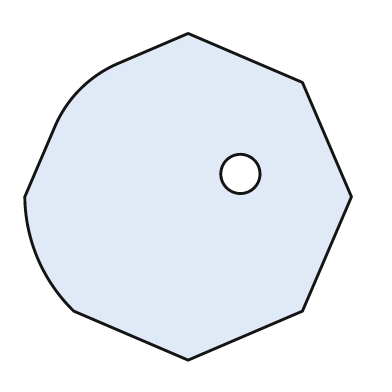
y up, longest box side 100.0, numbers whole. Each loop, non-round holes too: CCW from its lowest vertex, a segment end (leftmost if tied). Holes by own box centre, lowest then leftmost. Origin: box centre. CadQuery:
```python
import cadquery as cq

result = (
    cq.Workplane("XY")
    .moveTo(0.0, -50.0)
    .lineTo(35.0, -35.0)
    .lineTo(50.0, 0.0)
    .lineTo(35.0, 35.0)
    .lineTo(0.0, 50.0)
    .lineTo(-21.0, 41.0)
    .threePointArc((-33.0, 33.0), (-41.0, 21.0))
    .lineTo(-50.0, 0.0)
    .threePointArc((-46.0, -19.0), (-35.0, -35.0))
    .close()
    .moveTo(16.0, 7.0)
    .circle(6.0)
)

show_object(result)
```